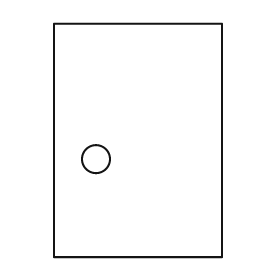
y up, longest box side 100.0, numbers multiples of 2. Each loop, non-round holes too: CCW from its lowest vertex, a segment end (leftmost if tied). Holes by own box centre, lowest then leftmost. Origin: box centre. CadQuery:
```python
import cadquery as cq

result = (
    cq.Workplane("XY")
    .moveTo(-36.0, -50.0)
    .lineTo(36.0, -50.0)
    .lineTo(36.0, 50.0)
    .lineTo(-36.0, 50.0)
    .close()
    .moveTo(-18.0, -8.0)
    .circle(6.0)
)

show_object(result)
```